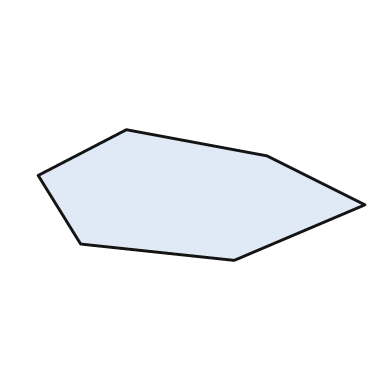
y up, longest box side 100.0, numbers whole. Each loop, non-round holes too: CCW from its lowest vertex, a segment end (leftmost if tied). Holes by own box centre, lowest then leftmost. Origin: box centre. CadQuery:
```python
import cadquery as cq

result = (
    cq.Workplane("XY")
    .moveTo(10.0, -20.0)
    .lineTo(50.0, -3.0)
    .lineTo(20.0, 12.0)
    .lineTo(-23.0, 20.0)
    .lineTo(-50.0, 6.0)
    .lineTo(-37.0, -15.0)
    .close()
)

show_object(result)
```